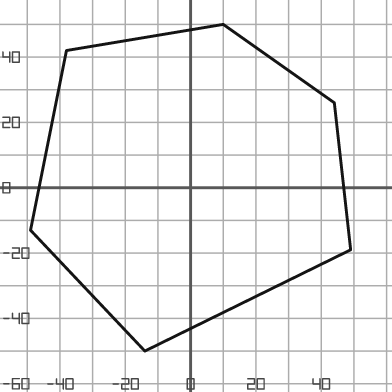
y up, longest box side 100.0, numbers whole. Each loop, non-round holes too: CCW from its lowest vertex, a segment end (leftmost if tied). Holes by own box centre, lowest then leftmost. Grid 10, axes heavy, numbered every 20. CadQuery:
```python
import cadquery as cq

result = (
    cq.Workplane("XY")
    .moveTo(-14.0, -50.0)
    .lineTo(49.0, -19.0)
    .lineTo(44.0, 26.0)
    .lineTo(10.0, 50.0)
    .lineTo(-38.0, 42.0)
    .lineTo(-49.0, -13.0)
    .close()
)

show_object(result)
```